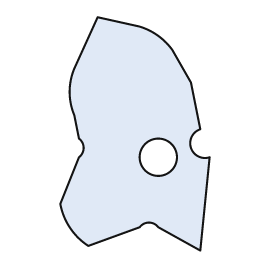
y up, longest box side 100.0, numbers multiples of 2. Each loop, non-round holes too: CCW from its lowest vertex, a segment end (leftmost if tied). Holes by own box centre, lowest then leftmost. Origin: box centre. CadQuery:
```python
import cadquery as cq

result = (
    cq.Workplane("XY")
    .moveTo(28.0, -50.0)
    .lineTo(32.0, -10.0)
    .threePointArc((24.0, -6.0), (28.0, 2.0))
    .lineTo(24.0, 22.0)
    .lineTo(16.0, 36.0)
    .threePointArc((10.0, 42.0), (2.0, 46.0))
    .lineTo(-16.0, 50.0)
    .lineTo(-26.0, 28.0)
    .threePointArc((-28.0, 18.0), (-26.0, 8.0))
    .lineTo(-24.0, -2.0)
    .threePointArc((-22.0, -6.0), (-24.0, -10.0))
    .lineTo(-32.0, -30.0)
    .threePointArc((-28.0, -40.0), (-20.0, -48.0))
    .lineTo(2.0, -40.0)
    .threePointArc((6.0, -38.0), (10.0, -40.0))
    .close()
    .moveTo(10.0, -10.0)
    .circle(8.0)
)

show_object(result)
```